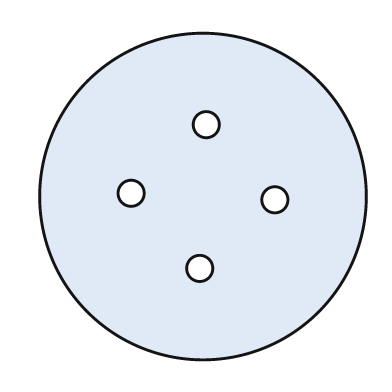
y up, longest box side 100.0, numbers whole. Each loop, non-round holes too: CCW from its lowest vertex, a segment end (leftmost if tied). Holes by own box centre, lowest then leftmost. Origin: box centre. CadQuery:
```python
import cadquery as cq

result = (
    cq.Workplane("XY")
    .moveTo(0.0, 0.0)
    .circle(50.0)
    .moveTo(-1.0, -22.0)
    .circle(4.0)
    .moveTo(22.0, -1.0)
    .circle(4.0)
    .moveTo(-22.0, 1.0)
    .circle(4.0)
    .moveTo(1.0, 22.0)
    .circle(4.0)
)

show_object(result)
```